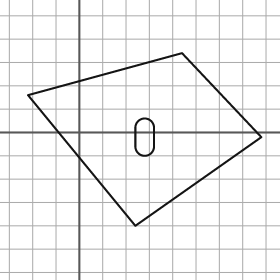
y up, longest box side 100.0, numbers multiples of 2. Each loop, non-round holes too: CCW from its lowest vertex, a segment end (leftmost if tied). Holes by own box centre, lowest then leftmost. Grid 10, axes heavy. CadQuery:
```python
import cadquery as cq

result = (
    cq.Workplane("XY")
    .moveTo(24.0, -40.0)
    .lineTo(78.0, -2.0)
    .lineTo(44.0, 34.0)
    .lineTo(-22.0, 16.0)
    .close()
    .moveTo(24.0, -6.0)
    .threePointArc((28.0, -10.0), (32.0, -6.0))
    .lineTo(32.0, 2.0)
    .threePointArc((28.0, 6.0), (24.0, 2.0))
    .close()
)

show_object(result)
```